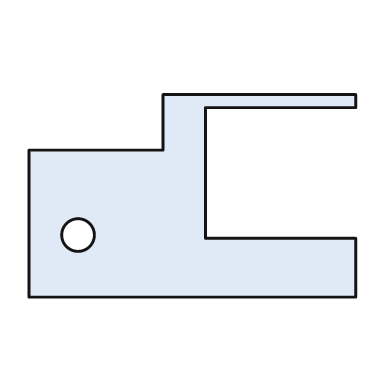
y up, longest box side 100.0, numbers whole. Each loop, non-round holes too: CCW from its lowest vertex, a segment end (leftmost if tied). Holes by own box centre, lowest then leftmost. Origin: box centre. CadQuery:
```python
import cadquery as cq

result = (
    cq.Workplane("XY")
    .moveTo(-50.0, -31.0)
    .lineTo(50.0, -31.0)
    .lineTo(50.0, -13.0)
    .lineTo(4.0, -13.0)
    .lineTo(4.0, 27.0)
    .lineTo(50.0, 27.0)
    .lineTo(50.0, 31.0)
    .lineTo(-9.0, 31.0)
    .lineTo(-9.0, 14.0)
    .lineTo(-50.0, 14.0)
    .close()
    .moveTo(-35.0, -12.0)
    .circle(5.0)
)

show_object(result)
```